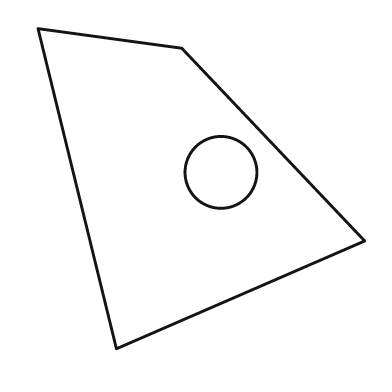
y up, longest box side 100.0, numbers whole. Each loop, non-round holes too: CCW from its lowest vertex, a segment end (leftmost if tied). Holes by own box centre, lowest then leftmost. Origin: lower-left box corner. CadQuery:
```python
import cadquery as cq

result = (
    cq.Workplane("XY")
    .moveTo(24.0, 0.0)
    .lineTo(100.0, 33.0)
    .lineTo(44.0, 92.0)
    .lineTo(0.0, 98.0)
    .close()
    .moveTo(56.0, 54.0)
    .circle(11.0)
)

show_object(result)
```